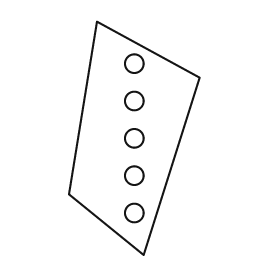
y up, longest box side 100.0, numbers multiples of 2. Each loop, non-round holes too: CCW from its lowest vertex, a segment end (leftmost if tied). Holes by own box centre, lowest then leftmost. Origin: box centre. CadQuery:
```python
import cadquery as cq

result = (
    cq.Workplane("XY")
    .moveTo(4.0, -50.0)
    .lineTo(28.0, 26.0)
    .lineTo(-16.0, 50.0)
    .lineTo(-28.0, -24.0)
    .close()
    .moveTo(0.0, -32.0)
    .circle(4.0)
    .moveTo(0.0, -16.0)
    .circle(4.0)
    .moveTo(0.0, 0.0)
    .circle(4.0)
    .moveTo(0.0, 16.0)
    .circle(4.0)
    .moveTo(0.0, 32.0)
    .circle(4.0)
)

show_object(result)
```